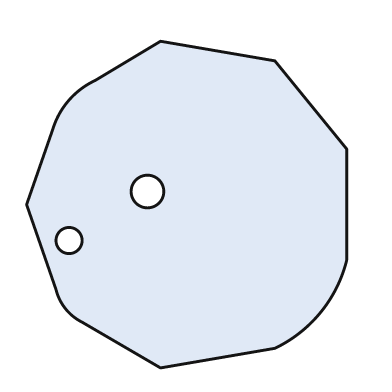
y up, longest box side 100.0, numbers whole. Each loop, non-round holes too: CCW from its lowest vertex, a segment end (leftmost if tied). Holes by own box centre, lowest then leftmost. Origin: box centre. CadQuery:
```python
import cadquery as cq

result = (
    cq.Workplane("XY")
    .moveTo(-8.0, -50.0)
    .lineTo(27.0, -44.0)
    .threePointArc((41.0, -33.0), (49.0, -17.0))
    .lineTo(49.0, 17.0)
    .lineTo(27.0, 44.0)
    .lineTo(-8.0, 50.0)
    .lineTo(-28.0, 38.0)
    .threePointArc((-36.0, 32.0), (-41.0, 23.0))
    .lineTo(-49.0, 0.0)
    .lineTo(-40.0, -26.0)
    .threePointArc((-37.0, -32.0), (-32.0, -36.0))
    .close()
    .moveTo(-36.0, -11.0)
    .circle(4.0)
    .moveTo(-12.0, 4.0)
    .circle(5.0)
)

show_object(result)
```